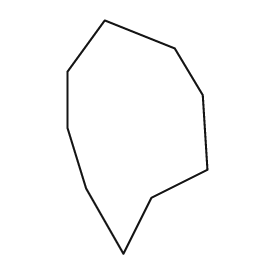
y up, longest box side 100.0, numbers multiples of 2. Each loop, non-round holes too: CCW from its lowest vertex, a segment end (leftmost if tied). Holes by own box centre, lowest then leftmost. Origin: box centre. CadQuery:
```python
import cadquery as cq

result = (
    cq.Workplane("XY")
    .moveTo(-6.0, -50.0)
    .lineTo(6.0, -26.0)
    .lineTo(30.0, -14.0)
    .lineTo(28.0, 18.0)
    .lineTo(16.0, 38.0)
    .lineTo(-14.0, 50.0)
    .lineTo(-30.0, 28.0)
    .lineTo(-30.0, 4.0)
    .lineTo(-22.0, -22.0)
    .close()
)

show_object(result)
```